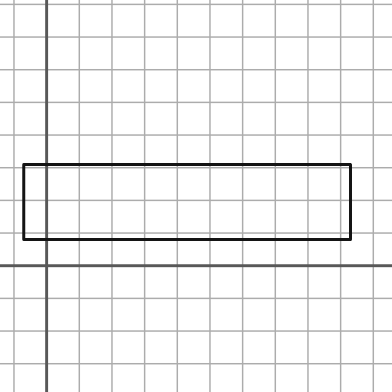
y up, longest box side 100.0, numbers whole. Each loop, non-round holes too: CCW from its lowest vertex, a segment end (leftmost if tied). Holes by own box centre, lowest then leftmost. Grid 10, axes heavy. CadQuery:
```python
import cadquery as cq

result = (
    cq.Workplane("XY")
    .moveTo(-7.0, 8.0)
    .lineTo(93.0, 8.0)
    .lineTo(93.0, 31.0)
    .lineTo(-7.0, 31.0)
    .close()
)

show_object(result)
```